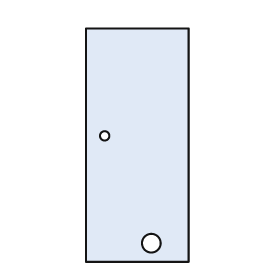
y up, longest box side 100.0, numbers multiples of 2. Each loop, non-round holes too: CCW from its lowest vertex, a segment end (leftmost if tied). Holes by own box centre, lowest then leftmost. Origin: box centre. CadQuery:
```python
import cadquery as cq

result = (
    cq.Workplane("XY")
    .moveTo(-22.0, -50.0)
    .lineTo(22.0, -50.0)
    .lineTo(22.0, 50.0)
    .lineTo(-22.0, 50.0)
    .close()
    .moveTo(6.0, -42.0)
    .circle(4.0)
    .moveTo(-14.0, 4.0)
    .circle(2.0)
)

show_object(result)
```